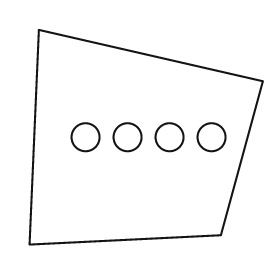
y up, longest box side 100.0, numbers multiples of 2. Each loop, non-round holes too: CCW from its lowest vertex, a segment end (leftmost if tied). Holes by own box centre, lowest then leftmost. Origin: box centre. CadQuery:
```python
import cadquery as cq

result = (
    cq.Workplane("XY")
    .moveTo(-50.0, -46.0)
    .lineTo(32.0, -42.0)
    .lineTo(50.0, 24.0)
    .lineTo(-46.0, 46.0)
    .close()
    .moveTo(-26.0, 0.0)
    .circle(6.0)
    .moveTo(-8.0, 0.0)
    .circle(6.0)
    .moveTo(10.0, 0.0)
    .circle(6.0)
    .moveTo(28.0, 0.0)
    .circle(6.0)
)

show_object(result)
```